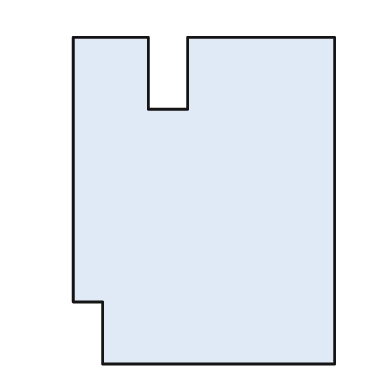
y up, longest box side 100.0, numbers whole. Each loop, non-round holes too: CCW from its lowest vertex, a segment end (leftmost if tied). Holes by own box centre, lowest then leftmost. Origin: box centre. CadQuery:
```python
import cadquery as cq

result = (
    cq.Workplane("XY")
    .moveTo(-31.0, -50.0)
    .lineTo(40.0, -50.0)
    .lineTo(40.0, 50.0)
    .lineTo(-5.0, 50.0)
    .lineTo(-5.0, 28.0)
    .lineTo(-17.0, 28.0)
    .lineTo(-17.0, 50.0)
    .lineTo(-40.0, 50.0)
    .lineTo(-40.0, -31.0)
    .lineTo(-31.0, -31.0)
    .close()
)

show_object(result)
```